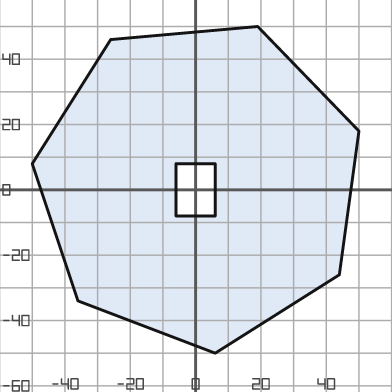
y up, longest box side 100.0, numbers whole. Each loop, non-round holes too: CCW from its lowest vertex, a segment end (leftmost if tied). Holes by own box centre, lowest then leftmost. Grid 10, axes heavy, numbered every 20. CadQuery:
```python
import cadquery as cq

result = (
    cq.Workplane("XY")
    .moveTo(6.0, -50.0)
    .lineTo(44.0, -26.0)
    .lineTo(50.0, 18.0)
    .lineTo(19.0, 50.0)
    .lineTo(-26.0, 46.0)
    .lineTo(-50.0, 8.0)
    .lineTo(-36.0, -34.0)
    .close()
    .moveTo(-6.0, -8.0)
    .lineTo(6.0, -8.0)
    .lineTo(6.0, 8.0)
    .lineTo(-6.0, 8.0)
    .close()
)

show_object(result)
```